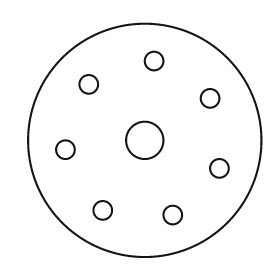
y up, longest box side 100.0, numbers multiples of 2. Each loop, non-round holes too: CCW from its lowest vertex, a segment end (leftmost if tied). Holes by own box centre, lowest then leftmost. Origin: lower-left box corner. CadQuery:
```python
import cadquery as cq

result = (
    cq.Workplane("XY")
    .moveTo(50.0, 50.0)
    .circle(50.0)
    .moveTo(62.0, 18.0)
    .circle(4.0)
    .moveTo(32.0, 20.0)
    .circle(4.0)
    .moveTo(82.0, 38.0)
    .circle(4.0)
    .moveTo(16.0, 46.0)
    .circle(4.0)
    .moveTo(50.0, 50.0)
    .circle(8.0)
    .moveTo(78.0, 68.0)
    .circle(4.0)
    .moveTo(26.0, 74.0)
    .circle(4.0)
    .moveTo(54.0, 84.0)
    .circle(4.0)
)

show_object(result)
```